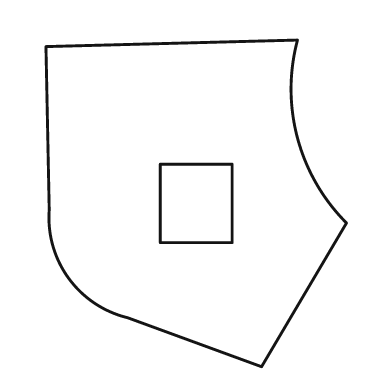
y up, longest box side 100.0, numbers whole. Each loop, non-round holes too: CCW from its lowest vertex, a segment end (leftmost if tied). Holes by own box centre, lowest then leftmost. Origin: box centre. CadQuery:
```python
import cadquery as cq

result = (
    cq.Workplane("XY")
    .moveTo(20.0, -50.0)
    .lineTo(46.0, -6.0)
    .threePointArc((31.0, 20.0), (31.0, 50.0))
    .lineTo(-46.0, 48.0)
    .lineTo(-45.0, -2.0)
    .threePointArc((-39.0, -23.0), (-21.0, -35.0))
    .close()
    .moveTo(-11.0, -12.0)
    .lineTo(11.0, -12.0)
    .lineTo(11.0, 12.0)
    .lineTo(-11.0, 12.0)
    .close()
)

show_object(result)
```